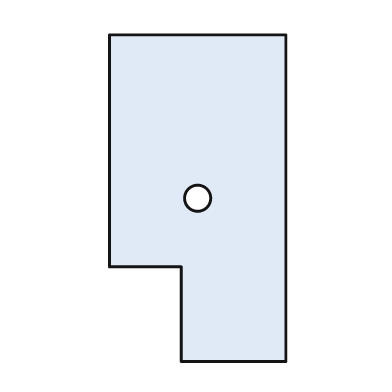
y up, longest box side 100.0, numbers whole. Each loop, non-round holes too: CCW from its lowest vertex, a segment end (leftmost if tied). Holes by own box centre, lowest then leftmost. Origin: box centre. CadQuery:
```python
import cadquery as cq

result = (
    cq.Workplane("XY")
    .moveTo(-5.0, -50.0)
    .lineTo(27.0, -50.0)
    .lineTo(27.0, 50.0)
    .lineTo(-27.0, 50.0)
    .lineTo(-27.0, -21.0)
    .lineTo(-5.0, -21.0)
    .close()
    .moveTo(0.0, 0.0)
    .circle(4.0)
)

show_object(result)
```